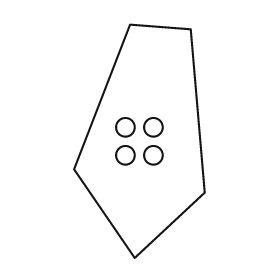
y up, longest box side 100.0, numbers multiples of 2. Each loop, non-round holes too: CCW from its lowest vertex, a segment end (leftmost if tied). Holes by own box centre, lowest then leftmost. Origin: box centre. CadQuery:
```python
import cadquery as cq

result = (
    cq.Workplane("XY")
    .moveTo(-2.0, -50.0)
    .lineTo(28.0, -22.0)
    .lineTo(22.0, 48.0)
    .lineTo(-4.0, 50.0)
    .lineTo(-28.0, -12.0)
    .close()
    .moveTo(-6.0, -6.0)
    .circle(4.0)
    .moveTo(6.0, -6.0)
    .circle(4.0)
    .moveTo(-6.0, 6.0)
    .circle(4.0)
    .moveTo(6.0, 6.0)
    .circle(4.0)
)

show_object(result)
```